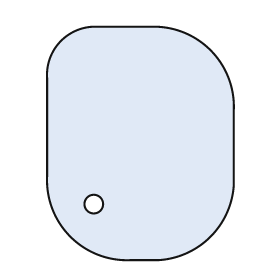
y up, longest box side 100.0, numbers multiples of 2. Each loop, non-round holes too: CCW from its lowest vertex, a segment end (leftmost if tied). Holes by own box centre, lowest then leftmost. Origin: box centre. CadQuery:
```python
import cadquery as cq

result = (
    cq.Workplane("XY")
    .moveTo(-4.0, -50.0)
    .lineTo(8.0, -50.0)
    .threePointArc((30.0, -40.0), (40.0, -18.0))
    .lineTo(40.0, 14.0)
    .threePointArc((30.0, 40.0), (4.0, 50.0))
    .lineTo(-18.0, 50.0)
    .threePointArc((-34.0, 44.0), (-40.0, 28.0))
    .lineTo(-40.0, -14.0)
    .threePointArc((-30.0, -40.0), (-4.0, -50.0))
    .close()
    .moveTo(-20.0, -26.0)
    .circle(4.0)
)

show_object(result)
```